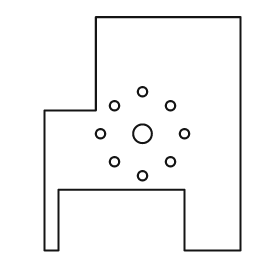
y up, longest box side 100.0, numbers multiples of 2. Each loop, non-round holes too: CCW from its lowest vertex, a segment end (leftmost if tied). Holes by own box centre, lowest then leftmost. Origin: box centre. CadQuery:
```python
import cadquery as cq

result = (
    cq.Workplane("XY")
    .moveTo(-42.0, -50.0)
    .lineTo(-36.0, -50.0)
    .lineTo(-36.0, -24.0)
    .lineTo(18.0, -24.0)
    .lineTo(18.0, -50.0)
    .lineTo(42.0, -50.0)
    .lineTo(42.0, 50.0)
    .lineTo(-20.0, 50.0)
    .lineTo(-20.0, 10.0)
    .lineTo(-42.0, 10.0)
    .close()
    .moveTo(0.0, -18.0)
    .circle(2.0)
    .moveTo(-12.0, -12.0)
    .circle(2.0)
    .moveTo(12.0, -12.0)
    .circle(2.0)
    .moveTo(-18.0, 0.0)
    .circle(2.0)
    .moveTo(0.0, 0.0)
    .circle(4.0)
    .moveTo(18.0, 0.0)
    .circle(2.0)
    .moveTo(-12.0, 12.0)
    .circle(2.0)
    .moveTo(12.0, 12.0)
    .circle(2.0)
    .moveTo(0.0, 18.0)
    .circle(2.0)
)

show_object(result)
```